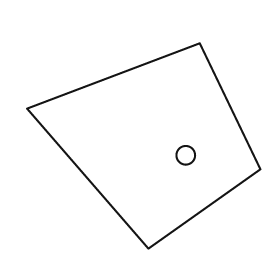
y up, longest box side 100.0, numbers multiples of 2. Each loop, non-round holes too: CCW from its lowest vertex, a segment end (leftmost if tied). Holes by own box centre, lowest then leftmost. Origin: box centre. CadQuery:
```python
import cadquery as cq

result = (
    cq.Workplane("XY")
    .moveTo(2.0, -44.0)
    .lineTo(50.0, -10.0)
    .lineTo(24.0, 44.0)
    .lineTo(-50.0, 16.0)
    .close()
    .moveTo(18.0, -4.0)
    .circle(4.0)
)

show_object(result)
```